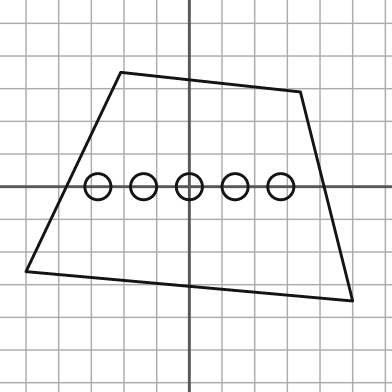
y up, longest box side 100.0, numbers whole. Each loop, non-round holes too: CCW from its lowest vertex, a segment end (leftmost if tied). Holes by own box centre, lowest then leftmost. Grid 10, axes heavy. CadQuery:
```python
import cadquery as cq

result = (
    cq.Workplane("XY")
    .moveTo(50.0, -35.0)
    .lineTo(34.0, 29.0)
    .lineTo(-21.0, 35.0)
    .lineTo(-50.0, -26.0)
    .close()
    .moveTo(-28.0, 0.0)
    .circle(4.0)
    .moveTo(-14.0, 0.0)
    .circle(4.0)
    .moveTo(0.0, 0.0)
    .circle(4.0)
    .moveTo(14.0, 0.0)
    .circle(4.0)
    .moveTo(28.0, 0.0)
    .circle(4.0)
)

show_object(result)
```